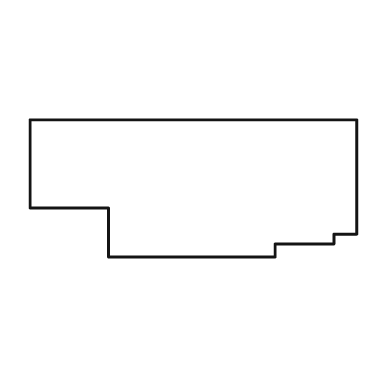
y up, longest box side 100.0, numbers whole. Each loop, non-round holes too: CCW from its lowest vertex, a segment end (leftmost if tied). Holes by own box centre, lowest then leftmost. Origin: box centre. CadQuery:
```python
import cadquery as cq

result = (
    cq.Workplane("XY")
    .moveTo(-26.0, -21.0)
    .lineTo(25.0, -21.0)
    .lineTo(25.0, -17.0)
    .lineTo(43.0, -17.0)
    .lineTo(43.0, -14.0)
    .lineTo(50.0, -14.0)
    .lineTo(50.0, 21.0)
    .lineTo(-50.0, 21.0)
    .lineTo(-50.0, -6.0)
    .lineTo(-26.0, -6.0)
    .close()
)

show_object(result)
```